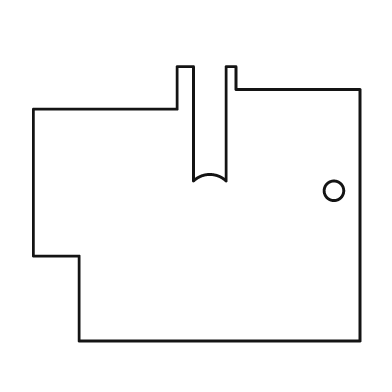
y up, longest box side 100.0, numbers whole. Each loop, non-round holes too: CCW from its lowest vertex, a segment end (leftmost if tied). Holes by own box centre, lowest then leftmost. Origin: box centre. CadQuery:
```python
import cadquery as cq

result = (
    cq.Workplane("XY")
    .moveTo(-36.0, -42.0)
    .lineTo(50.0, -42.0)
    .lineTo(50.0, 35.0)
    .lineTo(12.0, 35.0)
    .lineTo(12.0, 42.0)
    .lineTo(9.0, 42.0)
    .lineTo(9.0, 7.0)
    .threePointArc((4.0, 9.0), (-1.0, 7.0))
    .lineTo(-1.0, 42.0)
    .lineTo(-6.0, 42.0)
    .lineTo(-6.0, 29.0)
    .lineTo(-50.0, 29.0)
    .lineTo(-50.0, -16.0)
    .lineTo(-36.0, -16.0)
    .close()
    .moveTo(42.0, 4.0)
    .circle(3.0)
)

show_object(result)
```